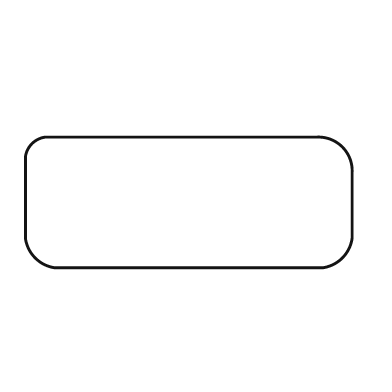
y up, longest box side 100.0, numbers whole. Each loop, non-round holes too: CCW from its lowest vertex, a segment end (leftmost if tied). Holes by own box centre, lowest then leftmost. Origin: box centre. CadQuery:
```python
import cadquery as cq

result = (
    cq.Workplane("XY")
    .moveTo(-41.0, -20.0)
    .lineTo(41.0, -20.0)
    .threePointArc((47.0, -17.0), (50.0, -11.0))
    .lineTo(50.0, 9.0)
    .threePointArc((47.0, 17.0), (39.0, 20.0))
    .lineTo(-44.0, 20.0)
    .threePointArc((-48.0, 18.0), (-50.0, 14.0))
    .lineTo(-50.0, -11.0)
    .threePointArc((-47.0, -17.0), (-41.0, -20.0))
    .close()
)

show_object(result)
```